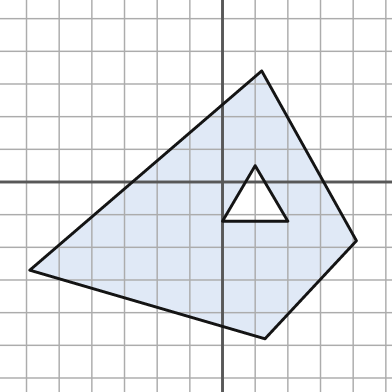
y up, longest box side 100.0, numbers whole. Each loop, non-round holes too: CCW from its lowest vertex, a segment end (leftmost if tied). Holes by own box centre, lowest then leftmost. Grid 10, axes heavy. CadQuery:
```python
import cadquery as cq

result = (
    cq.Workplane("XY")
    .moveTo(13.0, -48.0)
    .lineTo(41.0, -18.0)
    .lineTo(12.0, 34.0)
    .lineTo(-59.0, -27.0)
    .close()
    .moveTo(0.0, -12.0)
    .lineTo(20.0, -12.0)
    .lineTo(10.0, 5.0)
    .close()
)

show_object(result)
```